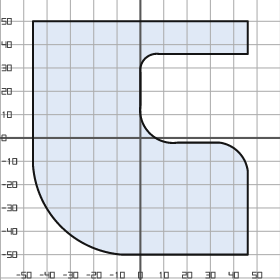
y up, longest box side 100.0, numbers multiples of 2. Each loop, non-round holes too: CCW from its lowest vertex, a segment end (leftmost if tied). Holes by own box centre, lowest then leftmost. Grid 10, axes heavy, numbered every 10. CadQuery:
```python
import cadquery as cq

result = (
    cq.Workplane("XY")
    .moveTo(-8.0, -50.0)
    .lineTo(46.0, -50.0)
    .lineTo(46.0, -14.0)
    .threePointArc((42.0, -6.0), (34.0, -2.0))
    .lineTo(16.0, -2.0)
    .threePointArc((4.0, 2.0), (0.0, 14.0))
    .lineTo(0.0, 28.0)
    .threePointArc((2.0, 34.0), (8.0, 36.0))
    .lineTo(46.0, 36.0)
    .lineTo(46.0, 50.0)
    .lineTo(-46.0, 50.0)
    .lineTo(-46.0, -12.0)
    .threePointArc((-34.0, -38.0), (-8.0, -50.0))
    .close()
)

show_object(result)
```